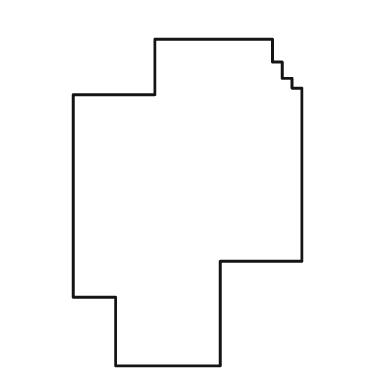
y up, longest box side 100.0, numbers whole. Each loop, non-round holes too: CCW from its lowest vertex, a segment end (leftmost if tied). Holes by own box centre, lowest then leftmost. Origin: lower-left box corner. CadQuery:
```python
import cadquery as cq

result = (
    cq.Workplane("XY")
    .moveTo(13.0, 0.0)
    .lineTo(45.0, 0.0)
    .lineTo(45.0, 32.0)
    .lineTo(70.0, 32.0)
    .lineTo(70.0, 85.0)
    .lineTo(67.0, 85.0)
    .lineTo(67.0, 88.0)
    .lineTo(64.0, 88.0)
    .lineTo(64.0, 93.0)
    .lineTo(61.0, 93.0)
    .lineTo(61.0, 100.0)
    .lineTo(25.0, 100.0)
    .lineTo(25.0, 83.0)
    .lineTo(0.0, 83.0)
    .lineTo(0.0, 21.0)
    .lineTo(13.0, 21.0)
    .close()
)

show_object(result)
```